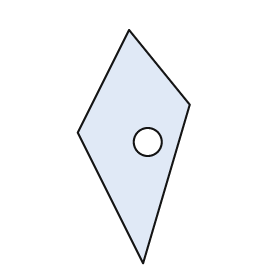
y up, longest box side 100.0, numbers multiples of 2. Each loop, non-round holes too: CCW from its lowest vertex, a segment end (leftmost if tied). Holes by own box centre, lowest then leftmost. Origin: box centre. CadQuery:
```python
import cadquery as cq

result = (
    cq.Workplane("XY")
    .moveTo(4.0, -50.0)
    .lineTo(24.0, 18.0)
    .lineTo(-2.0, 50.0)
    .lineTo(-24.0, 6.0)
    .close()
    .moveTo(6.0, 2.0)
    .circle(6.0)
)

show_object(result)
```